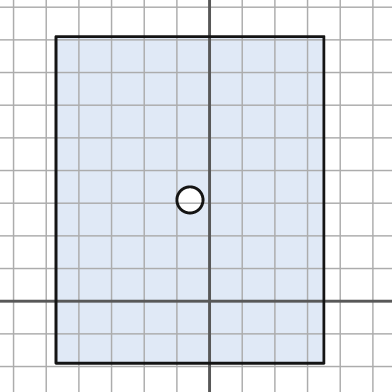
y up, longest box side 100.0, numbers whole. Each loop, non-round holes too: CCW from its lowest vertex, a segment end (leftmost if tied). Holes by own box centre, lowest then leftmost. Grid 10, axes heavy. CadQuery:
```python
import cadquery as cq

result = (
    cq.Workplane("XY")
    .moveTo(-47.0, -19.0)
    .lineTo(35.0, -19.0)
    .lineTo(35.0, 81.0)
    .lineTo(-47.0, 81.0)
    .close()
    .moveTo(-6.0, 31.0)
    .circle(4.0)
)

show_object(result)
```